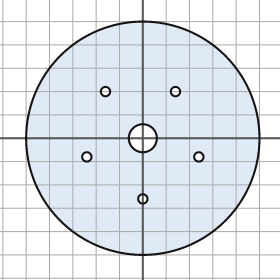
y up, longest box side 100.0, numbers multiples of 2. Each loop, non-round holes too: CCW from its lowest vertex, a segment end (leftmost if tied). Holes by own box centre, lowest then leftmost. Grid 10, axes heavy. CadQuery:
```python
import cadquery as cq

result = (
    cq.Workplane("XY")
    .moveTo(0.0, 0.0)
    .circle(50.0)
    .moveTo(0.0, -26.0)
    .circle(2.0)
    .moveTo(-24.0, -8.0)
    .circle(2.0)
    .moveTo(24.0, -8.0)
    .circle(2.0)
    .moveTo(0.0, 0.0)
    .circle(6.0)
    .moveTo(-16.0, 20.0)
    .circle(2.0)
    .moveTo(14.0, 20.0)
    .circle(2.0)
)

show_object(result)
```